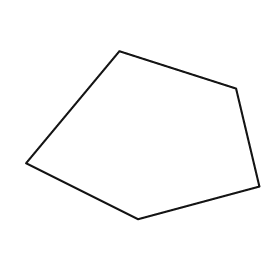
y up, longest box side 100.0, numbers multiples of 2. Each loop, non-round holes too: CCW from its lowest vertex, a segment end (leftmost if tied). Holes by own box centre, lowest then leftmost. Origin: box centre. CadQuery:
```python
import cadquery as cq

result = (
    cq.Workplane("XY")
    .moveTo(-2.0, -36.0)
    .lineTo(50.0, -22.0)
    .lineTo(40.0, 20.0)
    .lineTo(-10.0, 36.0)
    .lineTo(-50.0, -12.0)
    .close()
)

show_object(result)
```